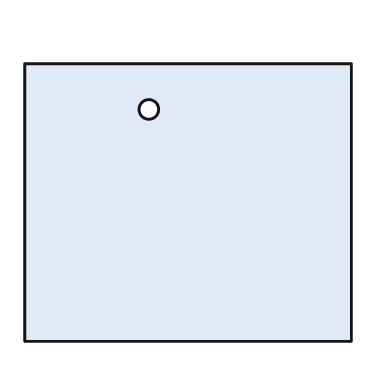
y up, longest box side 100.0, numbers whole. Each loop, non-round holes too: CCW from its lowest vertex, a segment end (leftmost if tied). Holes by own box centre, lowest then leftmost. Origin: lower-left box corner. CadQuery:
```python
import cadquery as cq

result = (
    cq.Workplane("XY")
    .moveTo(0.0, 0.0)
    .lineTo(100.0, 0.0)
    .lineTo(100.0, 85.0)
    .lineTo(0.0, 85.0)
    .close()
    .moveTo(38.0, 71.0)
    .circle(3.0)
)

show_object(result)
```